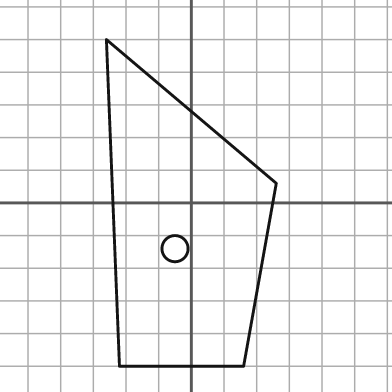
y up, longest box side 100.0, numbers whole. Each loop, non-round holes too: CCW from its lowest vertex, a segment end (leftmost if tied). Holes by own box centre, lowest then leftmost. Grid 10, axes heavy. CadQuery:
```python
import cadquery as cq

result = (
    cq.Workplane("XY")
    .moveTo(-22.0, -50.0)
    .lineTo(16.0, -50.0)
    .lineTo(26.0, 6.0)
    .lineTo(-26.0, 50.0)
    .close()
    .moveTo(-5.0, -14.0)
    .circle(4.0)
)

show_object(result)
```